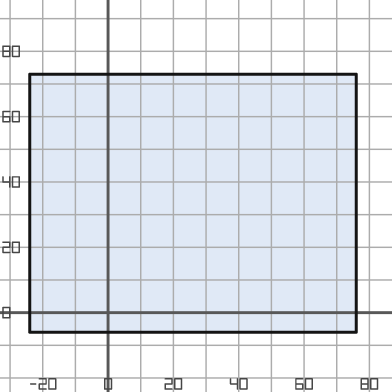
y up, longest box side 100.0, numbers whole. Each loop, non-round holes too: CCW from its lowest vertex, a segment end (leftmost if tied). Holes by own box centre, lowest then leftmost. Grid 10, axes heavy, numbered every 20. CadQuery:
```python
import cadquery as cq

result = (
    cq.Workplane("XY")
    .moveTo(-24.0, -6.0)
    .lineTo(76.0, -6.0)
    .lineTo(76.0, 73.0)
    .lineTo(-24.0, 73.0)
    .close()
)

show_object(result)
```